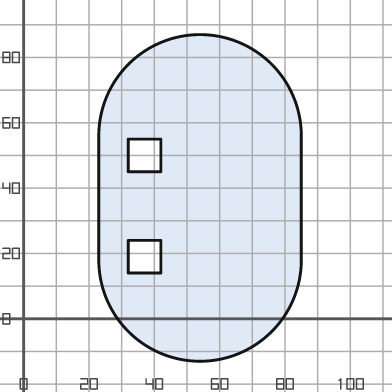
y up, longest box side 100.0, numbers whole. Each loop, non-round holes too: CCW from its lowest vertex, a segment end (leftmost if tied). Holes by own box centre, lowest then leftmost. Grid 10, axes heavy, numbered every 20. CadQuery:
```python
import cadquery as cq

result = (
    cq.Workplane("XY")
    .moveTo(23.0, 18.0)
    .threePointArc((54.0, -13.0), (85.0, 18.0))
    .lineTo(85.0, 56.0)
    .threePointArc((54.0, 87.0), (23.0, 56.0))
    .close()
    .moveTo(32.0, 14.0)
    .lineTo(42.0, 14.0)
    .lineTo(42.0, 24.0)
    .lineTo(32.0, 24.0)
    .close()
    .moveTo(32.0, 45.0)
    .lineTo(42.0, 45.0)
    .lineTo(42.0, 55.0)
    .lineTo(32.0, 55.0)
    .close()
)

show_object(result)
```